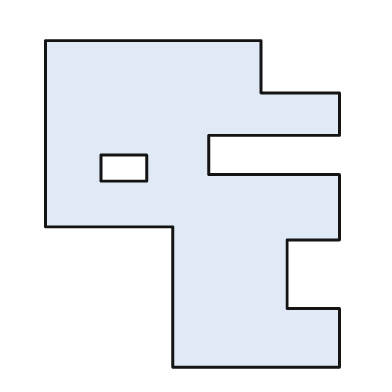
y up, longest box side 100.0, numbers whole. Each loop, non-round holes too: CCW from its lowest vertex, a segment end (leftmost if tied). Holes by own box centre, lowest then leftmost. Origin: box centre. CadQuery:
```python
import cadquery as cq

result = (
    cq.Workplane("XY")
    .moveTo(-6.0, -50.0)
    .lineTo(45.0, -50.0)
    .lineTo(45.0, -32.0)
    .lineTo(29.0, -32.0)
    .lineTo(29.0, -11.0)
    .lineTo(45.0, -11.0)
    .lineTo(45.0, 9.0)
    .lineTo(5.0, 9.0)
    .lineTo(5.0, 21.0)
    .lineTo(45.0, 21.0)
    .lineTo(45.0, 34.0)
    .lineTo(21.0, 34.0)
    .lineTo(21.0, 50.0)
    .lineTo(-45.0, 50.0)
    .lineTo(-45.0, -7.0)
    .lineTo(-6.0, -7.0)
    .close()
    .moveTo(-28.0, 7.0)
    .lineTo(-14.0, 7.0)
    .lineTo(-14.0, 15.0)
    .lineTo(-28.0, 15.0)
    .close()
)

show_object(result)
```